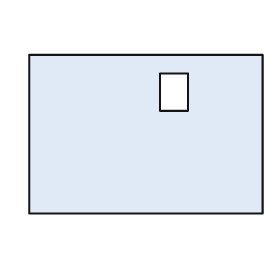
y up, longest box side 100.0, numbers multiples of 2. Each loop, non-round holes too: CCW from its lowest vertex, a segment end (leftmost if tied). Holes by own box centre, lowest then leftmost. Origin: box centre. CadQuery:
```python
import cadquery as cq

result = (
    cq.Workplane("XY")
    .moveTo(-50.0, -34.0)
    .lineTo(50.0, -34.0)
    .lineTo(50.0, 34.0)
    .lineTo(-50.0, 34.0)
    .close()
    .moveTo(6.0, 10.0)
    .lineTo(18.0, 10.0)
    .lineTo(18.0, 26.0)
    .lineTo(6.0, 26.0)
    .close()
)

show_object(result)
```